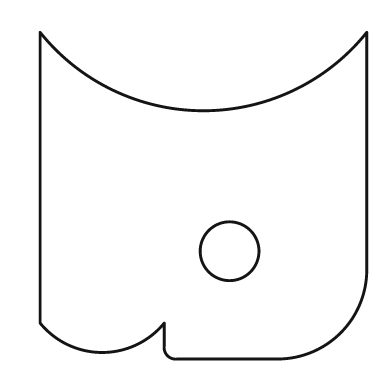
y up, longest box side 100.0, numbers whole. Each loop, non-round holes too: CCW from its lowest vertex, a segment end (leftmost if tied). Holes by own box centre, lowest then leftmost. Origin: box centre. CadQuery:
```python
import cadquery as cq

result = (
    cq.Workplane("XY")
    .moveTo(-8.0, -50.0)
    .lineTo(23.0, -50.0)
    .threePointArc((42.0, -42.0), (50.0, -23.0))
    .lineTo(50.0, 50.0)
    .threePointArc((0.0, 26.0), (-50.0, 50.0))
    .lineTo(-50.0, -39.0)
    .threePointArc((-31.0, -48.0), (-12.0, -39.0))
    .lineTo(-12.0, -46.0)
    .threePointArc((-11.0, -49.0), (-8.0, -50.0))
    .close()
    .moveTo(8.0, -17.0)
    .circle(9.0)
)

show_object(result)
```